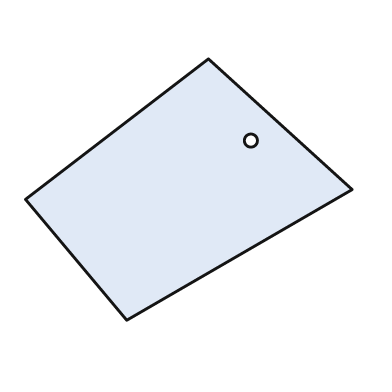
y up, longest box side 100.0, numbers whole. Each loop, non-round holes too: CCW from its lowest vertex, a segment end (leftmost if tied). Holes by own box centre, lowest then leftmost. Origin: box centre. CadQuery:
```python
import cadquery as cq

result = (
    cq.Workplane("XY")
    .moveTo(-19.0, -40.0)
    .lineTo(50.0, 0.0)
    .lineTo(6.0, 40.0)
    .lineTo(-50.0, -3.0)
    .close()
    .moveTo(19.0, 15.0)
    .circle(2.0)
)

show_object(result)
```